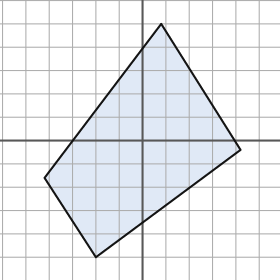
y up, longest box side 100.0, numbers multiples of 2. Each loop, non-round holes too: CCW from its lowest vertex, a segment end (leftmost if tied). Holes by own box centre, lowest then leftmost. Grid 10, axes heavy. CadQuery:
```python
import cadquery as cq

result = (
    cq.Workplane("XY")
    .moveTo(-20.0, -50.0)
    .lineTo(42.0, -4.0)
    .lineTo(8.0, 50.0)
    .lineTo(-42.0, -16.0)
    .close()
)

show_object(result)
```